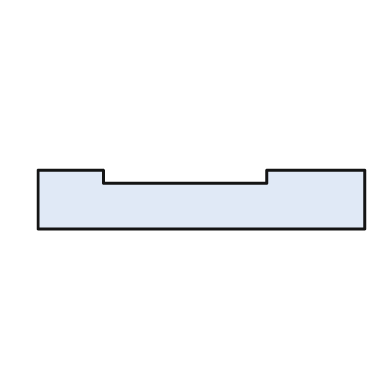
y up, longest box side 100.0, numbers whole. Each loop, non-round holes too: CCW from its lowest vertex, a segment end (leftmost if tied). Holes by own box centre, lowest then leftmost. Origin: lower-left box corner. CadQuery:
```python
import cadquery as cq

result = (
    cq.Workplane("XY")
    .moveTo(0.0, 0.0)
    .lineTo(100.0, 0.0)
    .lineTo(100.0, 18.0)
    .lineTo(70.0, 18.0)
    .lineTo(70.0, 14.0)
    .lineTo(20.0, 14.0)
    .lineTo(20.0, 18.0)
    .lineTo(0.0, 18.0)
    .close()
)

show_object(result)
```